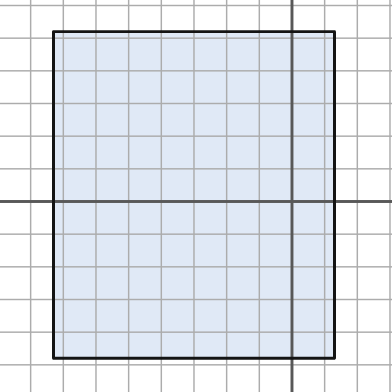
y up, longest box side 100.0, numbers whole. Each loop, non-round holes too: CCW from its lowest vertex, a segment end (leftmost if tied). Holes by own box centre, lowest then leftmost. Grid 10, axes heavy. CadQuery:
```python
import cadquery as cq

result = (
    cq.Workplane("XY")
    .moveTo(-73.0, -48.0)
    .lineTo(13.0, -48.0)
    .lineTo(13.0, 52.0)
    .lineTo(-73.0, 52.0)
    .close()
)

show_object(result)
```